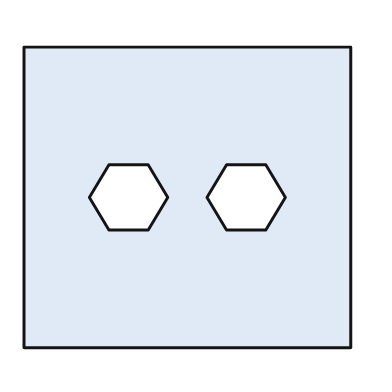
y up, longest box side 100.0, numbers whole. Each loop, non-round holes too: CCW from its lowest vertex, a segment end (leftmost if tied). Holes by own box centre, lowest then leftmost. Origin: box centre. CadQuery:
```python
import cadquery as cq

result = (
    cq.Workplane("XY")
    .moveTo(-50.0, -46.0)
    .lineTo(50.0, -46.0)
    .lineTo(50.0, 46.0)
    .lineTo(-50.0, 46.0)
    .close()
    .moveTo(-24.0, -10.0)
    .lineTo(-12.0, -10.0)
    .lineTo(-6.0, 0.0)
    .lineTo(-12.0, 10.0)
    .lineTo(-24.0, 10.0)
    .lineTo(-30.0, 0.0)
    .close()
    .moveTo(12.0, -10.0)
    .lineTo(24.0, -10.0)
    .lineTo(30.0, 0.0)
    .lineTo(24.0, 10.0)
    .lineTo(12.0, 10.0)
    .lineTo(6.0, 0.0)
    .close()
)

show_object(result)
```